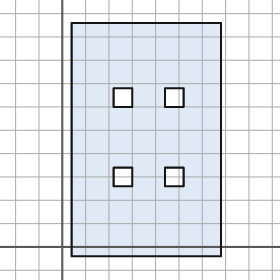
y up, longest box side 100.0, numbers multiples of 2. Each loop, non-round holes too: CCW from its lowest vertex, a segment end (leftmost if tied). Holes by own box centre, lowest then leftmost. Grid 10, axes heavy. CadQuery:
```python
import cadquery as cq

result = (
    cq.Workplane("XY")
    .moveTo(4.0, -4.0)
    .lineTo(68.0, -4.0)
    .lineTo(68.0, 96.0)
    .lineTo(4.0, 96.0)
    .close()
    .moveTo(22.0, 26.0)
    .lineTo(30.0, 26.0)
    .lineTo(30.0, 34.0)
    .lineTo(22.0, 34.0)
    .close()
    .moveTo(44.0, 26.0)
    .lineTo(52.0, 26.0)
    .lineTo(52.0, 34.0)
    .lineTo(44.0, 34.0)
    .close()
    .moveTo(22.0, 60.0)
    .lineTo(30.0, 60.0)
    .lineTo(30.0, 68.0)
    .lineTo(22.0, 68.0)
    .close()
    .moveTo(44.0, 60.0)
    .lineTo(52.0, 60.0)
    .lineTo(52.0, 68.0)
    .lineTo(44.0, 68.0)
    .close()
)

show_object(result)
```